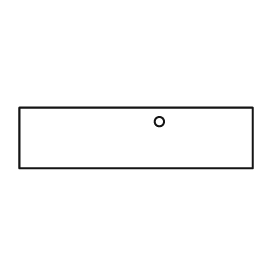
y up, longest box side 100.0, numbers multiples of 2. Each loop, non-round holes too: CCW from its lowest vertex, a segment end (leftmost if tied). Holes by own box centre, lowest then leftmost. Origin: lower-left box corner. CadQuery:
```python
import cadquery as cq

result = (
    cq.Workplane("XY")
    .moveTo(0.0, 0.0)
    .lineTo(100.0, 0.0)
    .lineTo(100.0, 26.0)
    .lineTo(0.0, 26.0)
    .close()
    .moveTo(60.0, 20.0)
    .circle(2.0)
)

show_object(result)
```